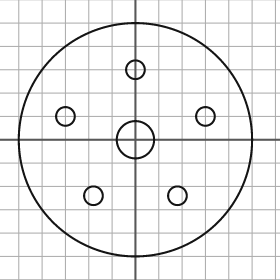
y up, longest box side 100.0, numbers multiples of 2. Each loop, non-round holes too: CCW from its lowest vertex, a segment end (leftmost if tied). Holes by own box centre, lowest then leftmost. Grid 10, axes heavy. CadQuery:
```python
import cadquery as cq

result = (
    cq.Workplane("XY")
    .moveTo(0.0, 0.0)
    .circle(50.0)
    .moveTo(-18.0, -24.0)
    .circle(4.0)
    .moveTo(18.0, -24.0)
    .circle(4.0)
    .moveTo(0.0, 0.0)
    .circle(8.0)
    .moveTo(-30.0, 10.0)
    .circle(4.0)
    .moveTo(30.0, 10.0)
    .circle(4.0)
    .moveTo(0.0, 30.0)
    .circle(4.0)
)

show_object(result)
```